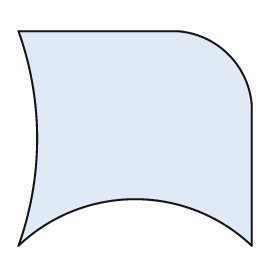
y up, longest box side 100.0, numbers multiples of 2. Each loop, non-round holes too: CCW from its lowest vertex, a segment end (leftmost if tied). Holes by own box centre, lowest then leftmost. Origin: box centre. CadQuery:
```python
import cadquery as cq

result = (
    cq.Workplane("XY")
    .moveTo(-50.0, -46.0)
    .threePointArc((0.0, -26.0), (50.0, -46.0))
    .lineTo(50.0, 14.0)
    .threePointArc((40.0, 36.0), (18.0, 46.0))
    .lineTo(-50.0, 46.0)
    .threePointArc((-42.0, 0.0), (-50.0, -46.0))
    .close()
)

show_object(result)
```